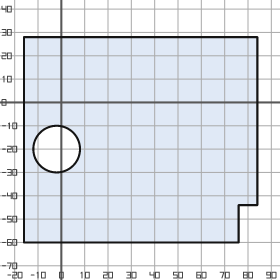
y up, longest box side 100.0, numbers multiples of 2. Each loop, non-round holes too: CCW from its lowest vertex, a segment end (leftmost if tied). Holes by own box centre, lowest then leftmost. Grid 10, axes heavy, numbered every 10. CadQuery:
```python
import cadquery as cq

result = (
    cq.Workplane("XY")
    .moveTo(-16.0, -60.0)
    .lineTo(76.0, -60.0)
    .lineTo(76.0, -44.0)
    .lineTo(84.0, -44.0)
    .lineTo(84.0, 28.0)
    .lineTo(-16.0, 28.0)
    .close()
    .moveTo(-2.0, -20.0)
    .circle(10.0)
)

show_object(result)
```